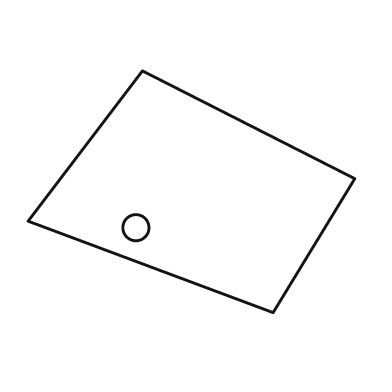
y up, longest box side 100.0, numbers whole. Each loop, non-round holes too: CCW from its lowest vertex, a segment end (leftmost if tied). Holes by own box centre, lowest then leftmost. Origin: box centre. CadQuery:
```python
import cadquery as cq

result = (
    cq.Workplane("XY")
    .moveTo(25.0, -37.0)
    .lineTo(50.0, 4.0)
    .lineTo(-15.0, 37.0)
    .lineTo(-50.0, -9.0)
    .close()
    .moveTo(-17.0, -11.0)
    .circle(4.0)
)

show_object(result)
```